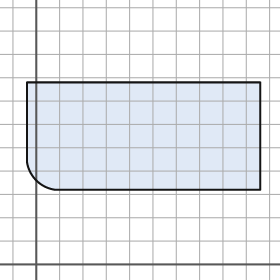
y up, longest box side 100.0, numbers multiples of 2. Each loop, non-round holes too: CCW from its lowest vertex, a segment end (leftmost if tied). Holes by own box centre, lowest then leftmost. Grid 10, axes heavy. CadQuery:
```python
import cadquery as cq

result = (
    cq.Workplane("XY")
    .moveTo(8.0, 32.0)
    .lineTo(96.0, 32.0)
    .lineTo(96.0, 78.0)
    .lineTo(-4.0, 78.0)
    .lineTo(-4.0, 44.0)
    .threePointArc((0.0, 36.0), (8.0, 32.0))
    .close()
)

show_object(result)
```